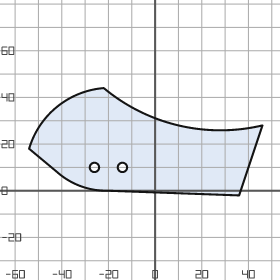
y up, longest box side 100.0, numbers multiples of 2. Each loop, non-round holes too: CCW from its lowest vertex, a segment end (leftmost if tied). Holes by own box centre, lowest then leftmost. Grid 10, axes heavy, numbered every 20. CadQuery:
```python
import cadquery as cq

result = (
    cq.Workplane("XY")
    .moveTo(36.0, -2.0)
    .lineTo(46.0, 28.0)
    .threePointArc((10.0, 28.0), (-22.0, 44.0))
    .threePointArc((-42.0, 36.0), (-54.0, 18.0))
    .lineTo(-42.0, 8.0)
    .threePointArc((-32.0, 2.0), (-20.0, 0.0))
    .close()
    .moveTo(-26.0, 10.0)
    .circle(2.0)
    .moveTo(-14.0, 10.0)
    .circle(2.0)
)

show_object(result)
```